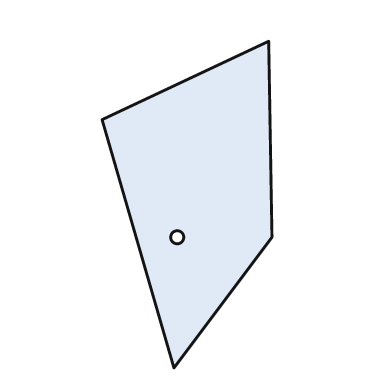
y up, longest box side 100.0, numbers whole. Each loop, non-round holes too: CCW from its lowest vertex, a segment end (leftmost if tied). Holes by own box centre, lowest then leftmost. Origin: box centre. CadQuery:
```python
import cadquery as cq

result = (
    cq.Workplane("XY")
    .moveTo(-4.0, -50.0)
    .lineTo(26.0, -10.0)
    .lineTo(25.0, 50.0)
    .lineTo(-26.0, 26.0)
    .close()
    .moveTo(-3.0, -10.0)
    .circle(2.0)
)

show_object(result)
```